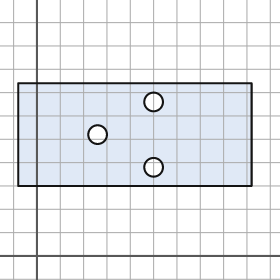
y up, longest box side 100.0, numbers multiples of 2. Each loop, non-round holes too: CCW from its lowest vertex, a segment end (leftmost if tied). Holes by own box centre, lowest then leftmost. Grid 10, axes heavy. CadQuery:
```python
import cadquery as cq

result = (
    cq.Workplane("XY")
    .moveTo(-8.0, 30.0)
    .lineTo(92.0, 30.0)
    .lineTo(92.0, 74.0)
    .lineTo(-8.0, 74.0)
    .close()
    .moveTo(50.0, 38.0)
    .circle(4.0)
    .moveTo(26.0, 52.0)
    .circle(4.0)
    .moveTo(50.0, 66.0)
    .circle(4.0)
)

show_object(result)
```